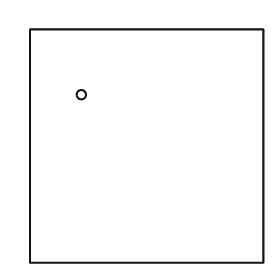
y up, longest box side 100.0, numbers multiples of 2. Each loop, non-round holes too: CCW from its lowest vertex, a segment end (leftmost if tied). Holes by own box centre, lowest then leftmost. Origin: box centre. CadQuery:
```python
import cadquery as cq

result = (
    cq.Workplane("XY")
    .moveTo(-50.0, -50.0)
    .lineTo(50.0, -50.0)
    .lineTo(50.0, 50.0)
    .lineTo(-50.0, 50.0)
    .close()
    .moveTo(-28.0, 22.0)
    .circle(2.0)
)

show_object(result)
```